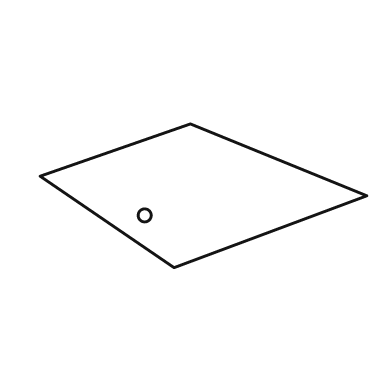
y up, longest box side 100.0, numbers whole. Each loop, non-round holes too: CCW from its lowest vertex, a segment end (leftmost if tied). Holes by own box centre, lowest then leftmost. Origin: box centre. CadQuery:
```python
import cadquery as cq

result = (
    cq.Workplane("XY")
    .moveTo(-9.0, -22.0)
    .lineTo(50.0, 0.0)
    .lineTo(-4.0, 22.0)
    .lineTo(-50.0, 6.0)
    .close()
    .moveTo(-18.0, -6.0)
    .circle(2.0)
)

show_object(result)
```